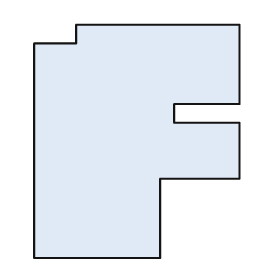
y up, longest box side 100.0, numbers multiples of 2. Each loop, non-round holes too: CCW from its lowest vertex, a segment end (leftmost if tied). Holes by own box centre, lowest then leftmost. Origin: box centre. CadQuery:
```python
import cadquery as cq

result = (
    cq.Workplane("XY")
    .moveTo(-44.0, -50.0)
    .lineTo(10.0, -50.0)
    .lineTo(10.0, -16.0)
    .lineTo(44.0, -16.0)
    .lineTo(44.0, 8.0)
    .lineTo(16.0, 8.0)
    .lineTo(16.0, 16.0)
    .lineTo(44.0, 16.0)
    .lineTo(44.0, 50.0)
    .lineTo(-26.0, 50.0)
    .lineTo(-26.0, 42.0)
    .lineTo(-44.0, 42.0)
    .close()
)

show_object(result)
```